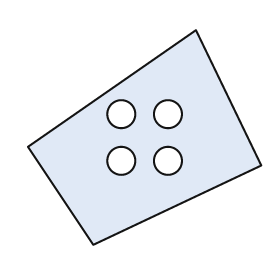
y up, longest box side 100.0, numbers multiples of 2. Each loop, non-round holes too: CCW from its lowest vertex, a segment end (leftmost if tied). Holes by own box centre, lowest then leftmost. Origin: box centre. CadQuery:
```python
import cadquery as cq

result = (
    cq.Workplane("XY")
    .moveTo(-22.0, -46.0)
    .lineTo(50.0, -12.0)
    .lineTo(22.0, 46.0)
    .lineTo(-50.0, -4.0)
    .close()
    .moveTo(-10.0, -10.0)
    .circle(6.0)
    .moveTo(10.0, -10.0)
    .circle(6.0)
    .moveTo(-10.0, 10.0)
    .circle(6.0)
    .moveTo(10.0, 10.0)
    .circle(6.0)
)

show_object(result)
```